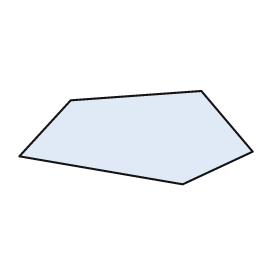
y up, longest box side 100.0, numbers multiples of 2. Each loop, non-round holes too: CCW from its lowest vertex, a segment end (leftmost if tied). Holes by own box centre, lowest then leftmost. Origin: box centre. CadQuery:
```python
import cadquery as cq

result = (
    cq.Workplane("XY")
    .moveTo(20.0, -20.0)
    .lineTo(50.0, -6.0)
    .lineTo(28.0, 20.0)
    .lineTo(-28.0, 16.0)
    .lineTo(-50.0, -8.0)
    .close()
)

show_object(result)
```